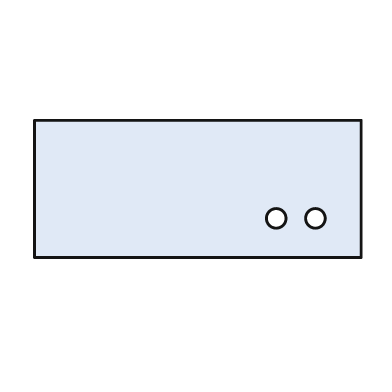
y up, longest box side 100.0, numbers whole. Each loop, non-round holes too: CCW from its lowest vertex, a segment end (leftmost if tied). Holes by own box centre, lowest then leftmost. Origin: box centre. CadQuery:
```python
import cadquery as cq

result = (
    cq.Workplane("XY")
    .moveTo(-50.0, -21.0)
    .lineTo(50.0, -21.0)
    .lineTo(50.0, 21.0)
    .lineTo(-50.0, 21.0)
    .close()
    .moveTo(24.0, -9.0)
    .circle(3.0)
    .moveTo(36.0, -9.0)
    .circle(3.0)
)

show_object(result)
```